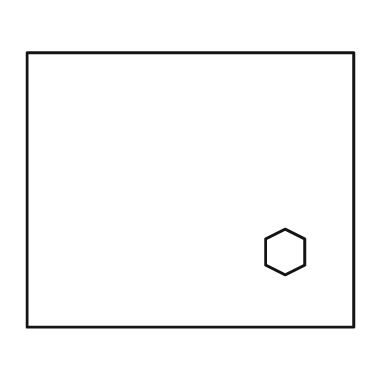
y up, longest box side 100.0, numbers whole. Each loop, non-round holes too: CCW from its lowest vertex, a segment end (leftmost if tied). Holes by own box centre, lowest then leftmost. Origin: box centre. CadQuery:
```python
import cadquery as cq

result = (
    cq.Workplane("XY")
    .moveTo(-50.0, -42.0)
    .lineTo(50.0, -42.0)
    .lineTo(50.0, 42.0)
    .lineTo(-50.0, 42.0)
    .close()
    .moveTo(29.0, -26.0)
    .lineTo(35.0, -23.0)
    .lineTo(35.0, -15.0)
    .lineTo(29.0, -12.0)
    .lineTo(23.0, -15.0)
    .lineTo(23.0, -23.0)
    .close()
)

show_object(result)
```